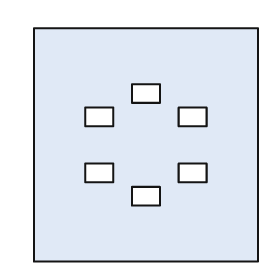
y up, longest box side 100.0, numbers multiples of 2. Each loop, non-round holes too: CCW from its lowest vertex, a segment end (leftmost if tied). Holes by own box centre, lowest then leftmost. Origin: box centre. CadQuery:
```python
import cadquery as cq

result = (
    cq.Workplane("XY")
    .moveTo(-48.0, -50.0)
    .lineTo(48.0, -50.0)
    .lineTo(48.0, 50.0)
    .lineTo(-48.0, 50.0)
    .close()
    .moveTo(-6.0, -26.0)
    .lineTo(6.0, -26.0)
    .lineTo(6.0, -18.0)
    .lineTo(-6.0, -18.0)
    .close()
    .moveTo(-26.0, -16.0)
    .lineTo(-14.0, -16.0)
    .lineTo(-14.0, -8.0)
    .lineTo(-26.0, -8.0)
    .close()
    .moveTo(14.0, -16.0)
    .lineTo(26.0, -16.0)
    .lineTo(26.0, -8.0)
    .lineTo(14.0, -8.0)
    .close()
    .moveTo(-26.0, 8.0)
    .lineTo(-14.0, 8.0)
    .lineTo(-14.0, 16.0)
    .lineTo(-26.0, 16.0)
    .close()
    .moveTo(14.0, 8.0)
    .lineTo(26.0, 8.0)
    .lineTo(26.0, 16.0)
    .lineTo(14.0, 16.0)
    .close()
    .moveTo(-6.0, 18.0)
    .lineTo(6.0, 18.0)
    .lineTo(6.0, 26.0)
    .lineTo(-6.0, 26.0)
    .close()
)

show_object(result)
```